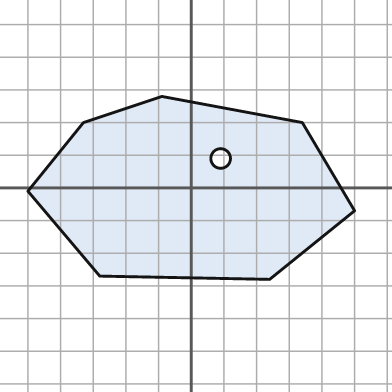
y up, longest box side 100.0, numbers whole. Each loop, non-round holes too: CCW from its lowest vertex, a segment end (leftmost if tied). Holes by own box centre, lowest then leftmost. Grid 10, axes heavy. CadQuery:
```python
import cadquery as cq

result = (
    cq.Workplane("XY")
    .moveTo(24.0, -28.0)
    .lineTo(50.0, -7.0)
    .lineTo(34.0, 20.0)
    .lineTo(-9.0, 28.0)
    .lineTo(-33.0, 20.0)
    .lineTo(-50.0, -1.0)
    .lineTo(-28.0, -27.0)
    .close()
    .moveTo(9.0, 9.0)
    .circle(3.0)
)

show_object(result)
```